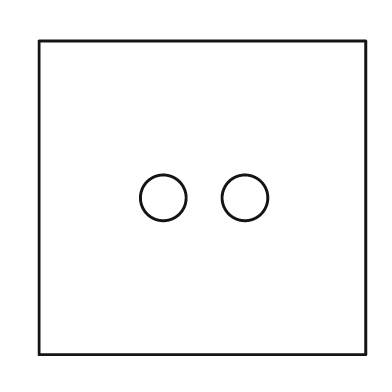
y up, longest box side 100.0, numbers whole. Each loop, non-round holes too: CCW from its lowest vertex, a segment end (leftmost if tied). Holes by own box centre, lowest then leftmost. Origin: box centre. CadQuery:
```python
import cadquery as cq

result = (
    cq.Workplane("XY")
    .moveTo(-50.0, -48.0)
    .lineTo(50.0, -48.0)
    .lineTo(50.0, 48.0)
    .lineTo(-50.0, 48.0)
    .close()
    .moveTo(-12.0, 0.0)
    .circle(7.0)
    .moveTo(13.0, 0.0)
    .circle(7.0)
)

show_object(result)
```